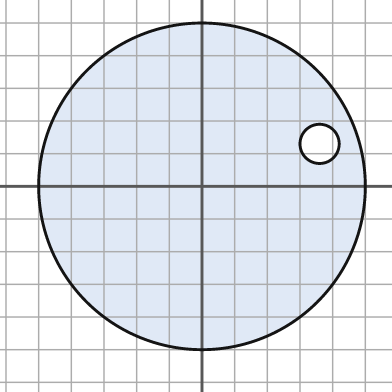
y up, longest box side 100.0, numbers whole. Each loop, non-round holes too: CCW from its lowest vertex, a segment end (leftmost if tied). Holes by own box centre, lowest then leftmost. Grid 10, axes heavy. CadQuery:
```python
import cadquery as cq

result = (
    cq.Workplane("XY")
    .moveTo(0.0, 0.0)
    .circle(50.0)
    .moveTo(36.0, 13.0)
    .circle(6.0)
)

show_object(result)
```